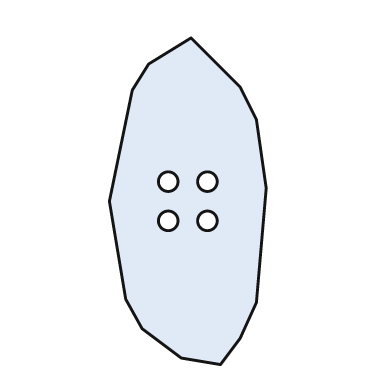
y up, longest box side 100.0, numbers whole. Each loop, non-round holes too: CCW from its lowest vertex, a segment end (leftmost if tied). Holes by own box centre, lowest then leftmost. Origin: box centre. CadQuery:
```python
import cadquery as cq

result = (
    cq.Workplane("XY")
    .moveTo(10.0, -50.0)
    .lineTo(16.0, -42.0)
    .lineTo(21.0, -31.0)
    .lineTo(24.0, 4.0)
    .lineTo(21.0, 25.0)
    .lineTo(16.0, 35.0)
    .lineTo(1.0, 50.0)
    .lineTo(-12.0, 42.0)
    .lineTo(-17.0, 34.0)
    .lineTo(-24.0, 0.0)
    .lineTo(-19.0, -30.0)
    .lineTo(-14.0, -39.0)
    .lineTo(-2.0, -48.0)
    .close()
    .moveTo(-6.0, -6.0)
    .circle(3.0)
    .moveTo(6.0, -6.0)
    .circle(3.0)
    .moveTo(-6.0, 6.0)
    .circle(3.0)
    .moveTo(6.0, 6.0)
    .circle(3.0)
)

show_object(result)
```